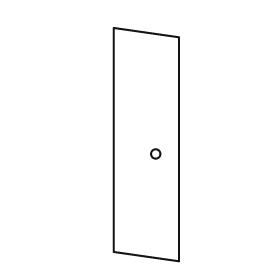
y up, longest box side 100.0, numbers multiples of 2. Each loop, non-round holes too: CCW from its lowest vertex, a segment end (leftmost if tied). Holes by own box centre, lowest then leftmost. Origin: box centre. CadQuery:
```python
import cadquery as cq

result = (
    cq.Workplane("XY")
    .moveTo(14.0, -50.0)
    .lineTo(14.0, 46.0)
    .lineTo(-14.0, 50.0)
    .lineTo(-14.0, -46.0)
    .close()
    .moveTo(4.0, -4.0)
    .circle(2.0)
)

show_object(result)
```